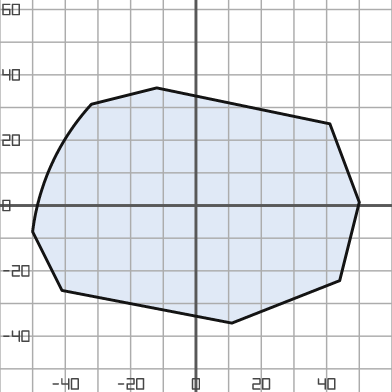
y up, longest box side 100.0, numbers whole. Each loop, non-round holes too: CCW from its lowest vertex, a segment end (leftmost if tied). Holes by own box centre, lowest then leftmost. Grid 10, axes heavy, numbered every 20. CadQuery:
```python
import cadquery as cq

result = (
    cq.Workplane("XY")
    .moveTo(11.0, -36.0)
    .lineTo(44.0, -23.0)
    .lineTo(50.0, 1.0)
    .lineTo(41.0, 25.0)
    .lineTo(-12.0, 36.0)
    .lineTo(-32.0, 31.0)
    .threePointArc((-44.0, 13.0), (-50.0, -8.0))
    .lineTo(-41.0, -26.0)
    .close()
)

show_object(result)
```